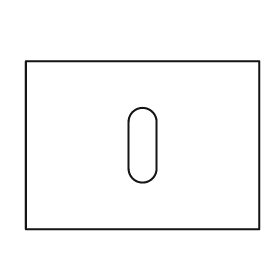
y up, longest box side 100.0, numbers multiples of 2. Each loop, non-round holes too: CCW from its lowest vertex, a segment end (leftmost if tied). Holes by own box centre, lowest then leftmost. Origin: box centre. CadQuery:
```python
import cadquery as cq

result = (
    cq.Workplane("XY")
    .moveTo(-50.0, -36.0)
    .lineTo(50.0, -36.0)
    .lineTo(50.0, 36.0)
    .lineTo(-50.0, 36.0)
    .close()
    .moveTo(-6.0, -10.0)
    .threePointArc((0.0, -16.0), (6.0, -10.0))
    .lineTo(6.0, 10.0)
    .threePointArc((0.0, 16.0), (-6.0, 10.0))
    .close()
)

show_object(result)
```